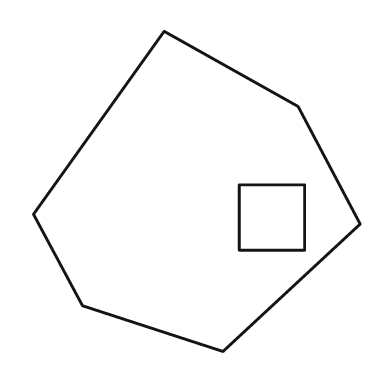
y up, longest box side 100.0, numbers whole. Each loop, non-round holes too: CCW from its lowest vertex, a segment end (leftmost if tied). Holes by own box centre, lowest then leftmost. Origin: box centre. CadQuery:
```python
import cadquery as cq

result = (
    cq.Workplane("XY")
    .moveTo(8.0, -49.0)
    .lineTo(50.0, -10.0)
    .lineTo(31.0, 26.0)
    .lineTo(-10.0, 49.0)
    .lineTo(-50.0, -7.0)
    .lineTo(-35.0, -35.0)
    .close()
    .moveTo(13.0, -18.0)
    .lineTo(33.0, -18.0)
    .lineTo(33.0, 2.0)
    .lineTo(13.0, 2.0)
    .close()
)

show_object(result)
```